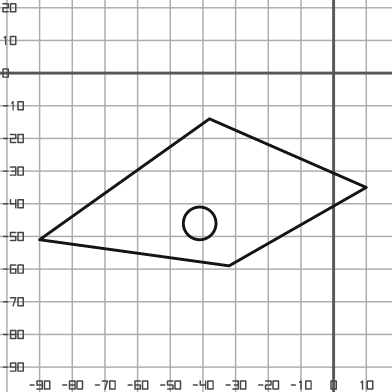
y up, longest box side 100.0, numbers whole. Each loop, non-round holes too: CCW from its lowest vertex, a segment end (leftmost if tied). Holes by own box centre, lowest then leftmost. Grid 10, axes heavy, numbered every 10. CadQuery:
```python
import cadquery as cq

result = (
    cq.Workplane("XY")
    .moveTo(-32.0, -59.0)
    .lineTo(10.0, -35.0)
    .lineTo(-38.0, -14.0)
    .lineTo(-90.0, -51.0)
    .close()
    .moveTo(-41.0, -46.0)
    .circle(5.0)
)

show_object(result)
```